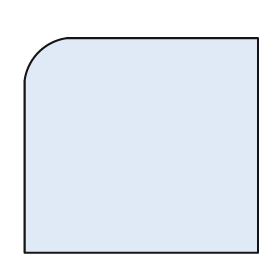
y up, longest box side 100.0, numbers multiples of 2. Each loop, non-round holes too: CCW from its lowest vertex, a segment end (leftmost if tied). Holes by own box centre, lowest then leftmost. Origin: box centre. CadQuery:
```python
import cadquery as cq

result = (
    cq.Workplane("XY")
    .moveTo(-50.0, -46.0)
    .lineTo(50.0, -46.0)
    .lineTo(50.0, 46.0)
    .lineTo(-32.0, 46.0)
    .threePointArc((-44.0, 40.0), (-50.0, 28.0))
    .close()
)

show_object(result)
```